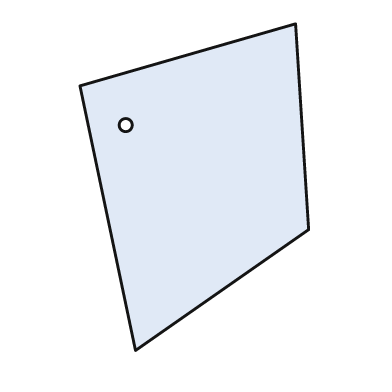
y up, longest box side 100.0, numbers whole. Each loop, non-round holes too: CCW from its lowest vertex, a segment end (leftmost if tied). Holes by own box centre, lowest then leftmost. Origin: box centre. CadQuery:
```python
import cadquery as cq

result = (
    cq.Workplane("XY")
    .moveTo(-18.0, -50.0)
    .lineTo(35.0, -13.0)
    .lineTo(31.0, 50.0)
    .lineTo(-35.0, 31.0)
    .close()
    .moveTo(-21.0, 19.0)
    .circle(2.0)
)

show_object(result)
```